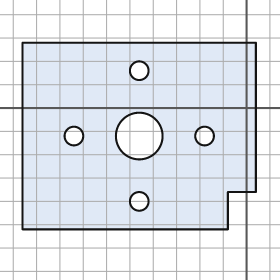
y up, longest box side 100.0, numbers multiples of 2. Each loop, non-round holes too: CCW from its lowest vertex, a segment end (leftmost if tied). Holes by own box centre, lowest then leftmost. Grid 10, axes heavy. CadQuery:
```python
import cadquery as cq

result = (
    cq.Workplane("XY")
    .moveTo(-96.0, -52.0)
    .lineTo(-8.0, -52.0)
    .lineTo(-8.0, -36.0)
    .lineTo(4.0, -36.0)
    .lineTo(4.0, 28.0)
    .lineTo(-96.0, 28.0)
    .close()
    .moveTo(-46.0, -40.0)
    .circle(4.0)
    .moveTo(-74.0, -12.0)
    .circle(4.0)
    .moveTo(-46.0, -12.0)
    .circle(10.0)
    .moveTo(-18.0, -12.0)
    .circle(4.0)
    .moveTo(-46.0, 16.0)
    .circle(4.0)
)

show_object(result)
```